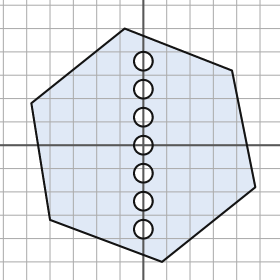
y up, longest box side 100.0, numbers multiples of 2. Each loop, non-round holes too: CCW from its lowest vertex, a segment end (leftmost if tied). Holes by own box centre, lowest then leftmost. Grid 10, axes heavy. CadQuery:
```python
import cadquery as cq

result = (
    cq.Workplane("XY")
    .moveTo(8.0, -50.0)
    .lineTo(48.0, -18.0)
    .lineTo(38.0, 32.0)
    .lineTo(-8.0, 50.0)
    .lineTo(-48.0, 18.0)
    .lineTo(-40.0, -32.0)
    .close()
    .moveTo(0.0, -36.0)
    .circle(4.0)
    .moveTo(0.0, -24.0)
    .circle(4.0)
    .moveTo(0.0, -12.0)
    .circle(4.0)
    .moveTo(0.0, 0.0)
    .circle(4.0)
    .moveTo(0.0, 12.0)
    .circle(4.0)
    .moveTo(0.0, 24.0)
    .circle(4.0)
    .moveTo(0.0, 36.0)
    .circle(4.0)
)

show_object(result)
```